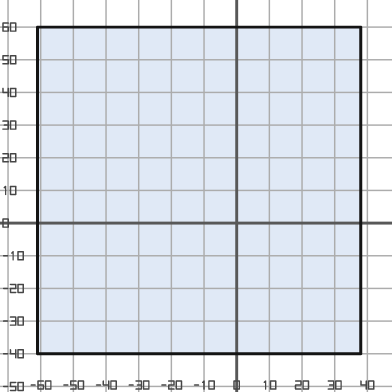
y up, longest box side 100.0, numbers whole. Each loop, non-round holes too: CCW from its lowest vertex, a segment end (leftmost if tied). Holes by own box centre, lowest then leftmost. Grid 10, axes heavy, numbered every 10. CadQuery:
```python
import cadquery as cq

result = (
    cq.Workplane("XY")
    .moveTo(-61.0, -40.0)
    .lineTo(38.0, -40.0)
    .lineTo(38.0, 60.0)
    .lineTo(-61.0, 60.0)
    .close()
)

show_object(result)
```